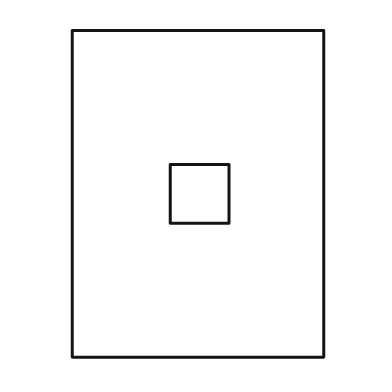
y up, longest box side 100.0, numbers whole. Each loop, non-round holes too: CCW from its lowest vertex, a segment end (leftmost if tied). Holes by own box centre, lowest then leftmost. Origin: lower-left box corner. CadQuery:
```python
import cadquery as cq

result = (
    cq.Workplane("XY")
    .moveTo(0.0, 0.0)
    .lineTo(77.0, 0.0)
    .lineTo(77.0, 100.0)
    .lineTo(0.0, 100.0)
    .close()
    .moveTo(30.0, 41.0)
    .lineTo(48.0, 41.0)
    .lineTo(48.0, 59.0)
    .lineTo(30.0, 59.0)
    .close()
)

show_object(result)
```